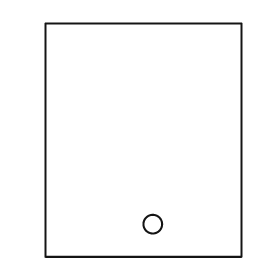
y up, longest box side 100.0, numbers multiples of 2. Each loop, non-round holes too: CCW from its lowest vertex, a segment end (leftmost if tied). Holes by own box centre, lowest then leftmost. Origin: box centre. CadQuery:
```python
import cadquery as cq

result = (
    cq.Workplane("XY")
    .moveTo(-42.0, -50.0)
    .lineTo(42.0, -50.0)
    .lineTo(42.0, 50.0)
    .lineTo(-42.0, 50.0)
    .close()
    .moveTo(4.0, -36.0)
    .circle(4.0)
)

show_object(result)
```